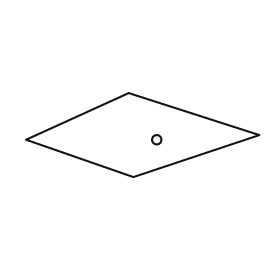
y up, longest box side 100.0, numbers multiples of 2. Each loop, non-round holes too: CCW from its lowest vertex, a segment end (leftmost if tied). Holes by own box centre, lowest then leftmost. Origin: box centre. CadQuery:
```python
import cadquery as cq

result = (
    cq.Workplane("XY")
    .moveTo(-4.0, -18.0)
    .lineTo(50.0, 0.0)
    .lineTo(-6.0, 18.0)
    .lineTo(-50.0, -2.0)
    .close()
    .moveTo(6.0, -2.0)
    .circle(2.0)
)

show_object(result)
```